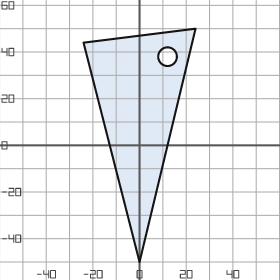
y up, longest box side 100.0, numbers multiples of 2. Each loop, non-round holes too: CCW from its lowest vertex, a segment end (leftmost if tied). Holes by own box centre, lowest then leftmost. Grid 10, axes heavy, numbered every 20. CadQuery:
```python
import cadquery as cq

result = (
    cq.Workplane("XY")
    .moveTo(0.0, -50.0)
    .lineTo(24.0, 50.0)
    .lineTo(-24.0, 44.0)
    .close()
    .moveTo(12.0, 38.0)
    .circle(4.0)
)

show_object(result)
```